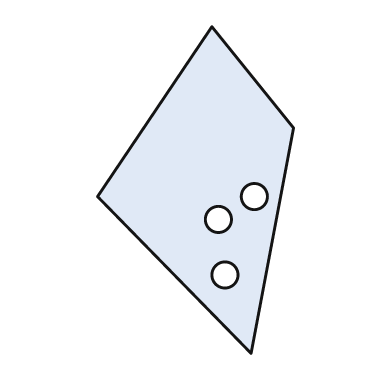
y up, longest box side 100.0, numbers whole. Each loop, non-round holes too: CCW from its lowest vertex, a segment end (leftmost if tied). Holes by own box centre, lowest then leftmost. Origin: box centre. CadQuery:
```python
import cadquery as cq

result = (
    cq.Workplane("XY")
    .moveTo(17.0, -50.0)
    .lineTo(30.0, 19.0)
    .lineTo(5.0, 50.0)
    .lineTo(-30.0, -2.0)
    .close()
    .moveTo(9.0, -26.0)
    .circle(4.0)
    .moveTo(7.0, -9.0)
    .circle(4.0)
    .moveTo(18.0, -2.0)
    .circle(4.0)
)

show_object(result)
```